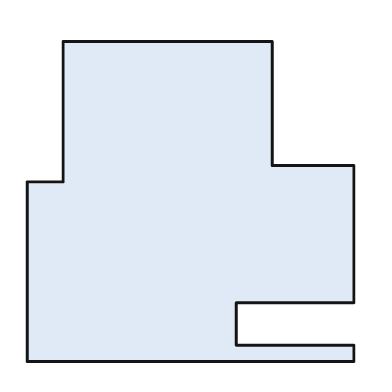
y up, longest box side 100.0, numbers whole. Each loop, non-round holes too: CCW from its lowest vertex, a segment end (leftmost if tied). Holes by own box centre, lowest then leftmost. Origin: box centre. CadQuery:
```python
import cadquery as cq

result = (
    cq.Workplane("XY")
    .moveTo(-50.0, -49.0)
    .lineTo(50.0, -49.0)
    .lineTo(50.0, -44.0)
    .lineTo(14.0, -44.0)
    .lineTo(14.0, -31.0)
    .lineTo(50.0, -31.0)
    .lineTo(50.0, 11.0)
    .lineTo(25.0, 11.0)
    .lineTo(25.0, 49.0)
    .lineTo(-39.0, 49.0)
    .lineTo(-39.0, 6.0)
    .lineTo(-50.0, 6.0)
    .close()
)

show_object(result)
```